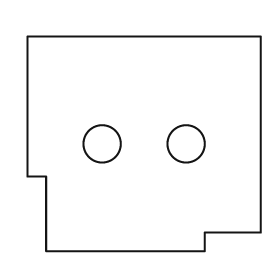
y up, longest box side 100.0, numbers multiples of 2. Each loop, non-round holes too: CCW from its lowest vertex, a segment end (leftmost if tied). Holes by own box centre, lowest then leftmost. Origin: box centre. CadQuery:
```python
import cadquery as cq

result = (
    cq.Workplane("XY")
    .moveTo(-42.0, -46.0)
    .lineTo(26.0, -46.0)
    .lineTo(26.0, -38.0)
    .lineTo(50.0, -38.0)
    .lineTo(50.0, 46.0)
    .lineTo(-50.0, 46.0)
    .lineTo(-50.0, -14.0)
    .lineTo(-42.0, -14.0)
    .close()
    .moveTo(-18.0, 0.0)
    .circle(8.0)
    .moveTo(18.0, 0.0)
    .circle(8.0)
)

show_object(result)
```